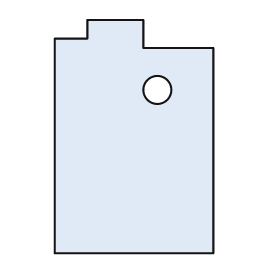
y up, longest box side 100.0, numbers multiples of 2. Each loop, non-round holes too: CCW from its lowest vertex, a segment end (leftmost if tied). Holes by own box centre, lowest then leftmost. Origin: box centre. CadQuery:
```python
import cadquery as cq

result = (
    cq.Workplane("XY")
    .moveTo(-34.0, -50.0)
    .lineTo(34.0, -50.0)
    .lineTo(34.0, 38.0)
    .lineTo(4.0, 38.0)
    .lineTo(4.0, 50.0)
    .lineTo(-20.0, 50.0)
    .lineTo(-20.0, 42.0)
    .lineTo(-34.0, 42.0)
    .close()
    .moveTo(10.0, 20.0)
    .circle(6.0)
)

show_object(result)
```